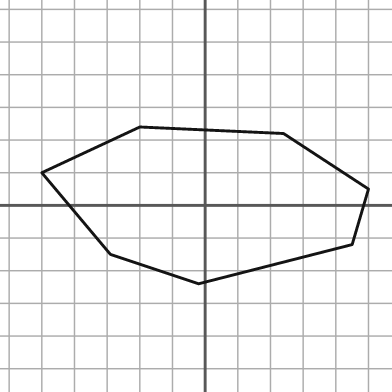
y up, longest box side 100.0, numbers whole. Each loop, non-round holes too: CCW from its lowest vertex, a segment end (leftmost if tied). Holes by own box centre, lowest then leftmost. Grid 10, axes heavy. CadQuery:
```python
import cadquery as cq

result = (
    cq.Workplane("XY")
    .moveTo(-2.0, -24.0)
    .lineTo(45.0, -12.0)
    .lineTo(50.0, 5.0)
    .lineTo(24.0, 22.0)
    .lineTo(-20.0, 24.0)
    .lineTo(-50.0, 10.0)
    .lineTo(-29.0, -15.0)
    .close()
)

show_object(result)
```